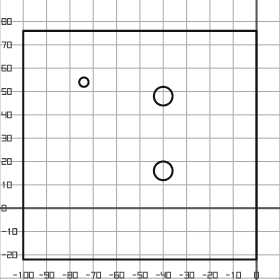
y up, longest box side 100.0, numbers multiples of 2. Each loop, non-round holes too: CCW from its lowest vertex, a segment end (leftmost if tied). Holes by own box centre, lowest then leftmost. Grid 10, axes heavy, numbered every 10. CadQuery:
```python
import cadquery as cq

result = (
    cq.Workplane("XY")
    .moveTo(-100.0, -22.0)
    .lineTo(0.0, -22.0)
    .lineTo(0.0, 76.0)
    .lineTo(-100.0, 76.0)
    .close()
    .moveTo(-40.0, 16.0)
    .circle(4.0)
    .moveTo(-40.0, 48.0)
    .circle(4.0)
    .moveTo(-74.0, 54.0)
    .circle(2.0)
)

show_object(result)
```